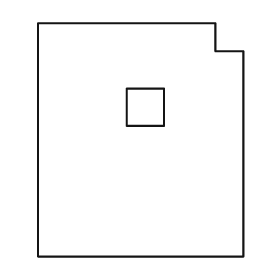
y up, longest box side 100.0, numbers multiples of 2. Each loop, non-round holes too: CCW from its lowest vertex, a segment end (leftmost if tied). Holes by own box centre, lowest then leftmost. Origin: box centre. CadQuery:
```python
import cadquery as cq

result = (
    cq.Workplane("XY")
    .moveTo(-44.0, -50.0)
    .lineTo(44.0, -50.0)
    .lineTo(44.0, 38.0)
    .lineTo(32.0, 38.0)
    .lineTo(32.0, 50.0)
    .lineTo(-44.0, 50.0)
    .close()
    .moveTo(-6.0, 6.0)
    .lineTo(10.0, 6.0)
    .lineTo(10.0, 22.0)
    .lineTo(-6.0, 22.0)
    .close()
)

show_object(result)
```